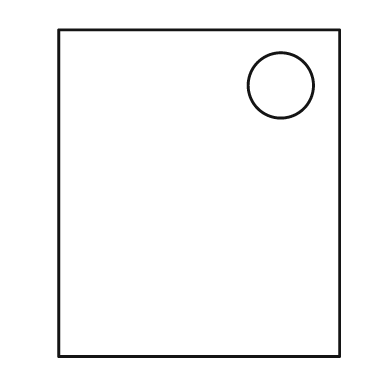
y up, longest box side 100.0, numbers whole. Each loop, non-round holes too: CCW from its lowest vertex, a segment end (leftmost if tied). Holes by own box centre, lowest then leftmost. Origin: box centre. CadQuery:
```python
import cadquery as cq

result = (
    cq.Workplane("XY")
    .moveTo(-43.0, -50.0)
    .lineTo(43.0, -50.0)
    .lineTo(43.0, 50.0)
    .lineTo(-43.0, 50.0)
    .close()
    .moveTo(25.0, 33.0)
    .circle(10.0)
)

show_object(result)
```